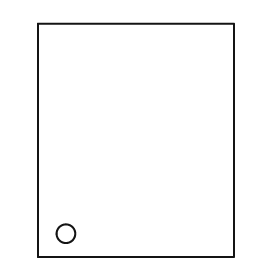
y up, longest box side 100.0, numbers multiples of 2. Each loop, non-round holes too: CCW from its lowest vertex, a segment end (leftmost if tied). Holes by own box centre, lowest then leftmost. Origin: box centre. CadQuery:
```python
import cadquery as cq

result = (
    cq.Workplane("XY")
    .moveTo(-42.0, -50.0)
    .lineTo(42.0, -50.0)
    .lineTo(42.0, 50.0)
    .lineTo(-42.0, 50.0)
    .close()
    .moveTo(-30.0, -40.0)
    .circle(4.0)
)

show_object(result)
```